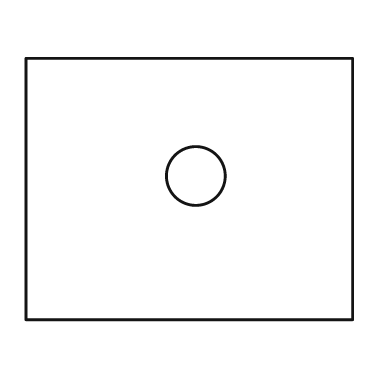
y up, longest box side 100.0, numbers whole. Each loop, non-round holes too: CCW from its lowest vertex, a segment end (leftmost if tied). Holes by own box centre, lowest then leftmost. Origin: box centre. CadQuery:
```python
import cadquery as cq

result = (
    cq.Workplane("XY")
    .moveTo(-50.0, -40.0)
    .lineTo(50.0, -40.0)
    .lineTo(50.0, 40.0)
    .lineTo(-50.0, 40.0)
    .close()
    .moveTo(2.0, 4.0)
    .circle(9.0)
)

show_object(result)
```